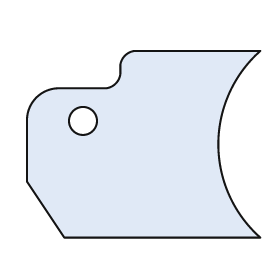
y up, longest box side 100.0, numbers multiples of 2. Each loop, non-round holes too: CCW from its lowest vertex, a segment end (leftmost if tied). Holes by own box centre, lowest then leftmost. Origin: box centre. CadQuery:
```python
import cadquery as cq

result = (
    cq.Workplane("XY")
    .moveTo(-34.0, -40.0)
    .lineTo(50.0, -40.0)
    .threePointArc((32.0, 0.0), (50.0, 40.0))
    .lineTo(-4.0, 40.0)
    .threePointArc((-8.0, 38.0), (-10.0, 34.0))
    .lineTo(-10.0, 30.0)
    .threePointArc((-12.0, 26.0), (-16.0, 24.0))
    .lineTo(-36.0, 24.0)
    .threePointArc((-46.0, 20.0), (-50.0, 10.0))
    .lineTo(-50.0, -16.0)
    .close()
    .moveTo(-26.0, 10.0)
    .circle(6.0)
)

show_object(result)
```